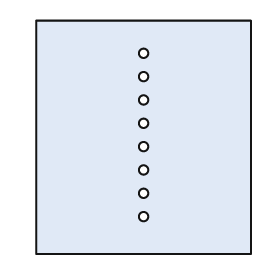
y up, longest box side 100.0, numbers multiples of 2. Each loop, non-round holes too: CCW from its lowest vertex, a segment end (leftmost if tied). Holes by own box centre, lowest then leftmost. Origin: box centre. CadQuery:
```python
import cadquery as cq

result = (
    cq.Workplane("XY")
    .moveTo(-46.0, -50.0)
    .lineTo(46.0, -50.0)
    .lineTo(46.0, 50.0)
    .lineTo(-46.0, 50.0)
    .close()
    .moveTo(0.0, -34.0)
    .circle(2.0)
    .moveTo(0.0, -24.0)
    .circle(2.0)
    .moveTo(0.0, -14.0)
    .circle(2.0)
    .moveTo(0.0, -4.0)
    .circle(2.0)
    .moveTo(0.0, 6.0)
    .circle(2.0)
    .moveTo(0.0, 16.0)
    .circle(2.0)
    .moveTo(0.0, 26.0)
    .circle(2.0)
    .moveTo(0.0, 36.0)
    .circle(2.0)
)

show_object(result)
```